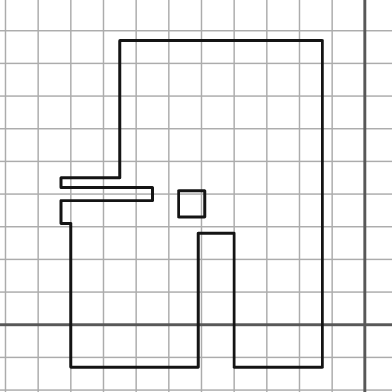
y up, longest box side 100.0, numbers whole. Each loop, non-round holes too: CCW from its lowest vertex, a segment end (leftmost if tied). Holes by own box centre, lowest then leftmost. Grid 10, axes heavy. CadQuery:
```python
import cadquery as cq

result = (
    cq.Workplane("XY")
    .moveTo(-90.0, -13.0)
    .lineTo(-51.0, -13.0)
    .lineTo(-51.0, 28.0)
    .lineTo(-40.0, 28.0)
    .lineTo(-40.0, -13.0)
    .lineTo(-13.0, -13.0)
    .lineTo(-13.0, 87.0)
    .lineTo(-75.0, 87.0)
    .lineTo(-75.0, 45.0)
    .lineTo(-93.0, 45.0)
    .lineTo(-93.0, 42.0)
    .lineTo(-65.0, 42.0)
    .lineTo(-65.0, 38.0)
    .lineTo(-93.0, 38.0)
    .lineTo(-93.0, 31.0)
    .lineTo(-90.0, 31.0)
    .close()
    .moveTo(-57.0, 33.0)
    .lineTo(-49.0, 33.0)
    .lineTo(-49.0, 41.0)
    .lineTo(-57.0, 41.0)
    .close()
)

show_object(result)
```